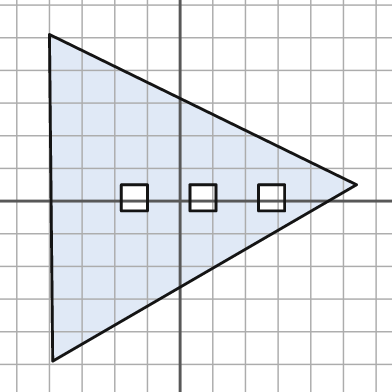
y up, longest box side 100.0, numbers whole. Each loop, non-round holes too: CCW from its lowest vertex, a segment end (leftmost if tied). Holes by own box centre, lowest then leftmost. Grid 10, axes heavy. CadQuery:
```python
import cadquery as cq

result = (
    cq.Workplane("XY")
    .moveTo(-39.0, -49.0)
    .lineTo(54.0, 5.0)
    .lineTo(-40.0, 51.0)
    .close()
    .moveTo(-18.0, -3.0)
    .lineTo(-10.0, -3.0)
    .lineTo(-10.0, 5.0)
    .lineTo(-18.0, 5.0)
    .close()
    .moveTo(3.0, -3.0)
    .lineTo(11.0, -3.0)
    .lineTo(11.0, 5.0)
    .lineTo(3.0, 5.0)
    .close()
    .moveTo(24.0, -3.0)
    .lineTo(32.0, -3.0)
    .lineTo(32.0, 5.0)
    .lineTo(24.0, 5.0)
    .close()
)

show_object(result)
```